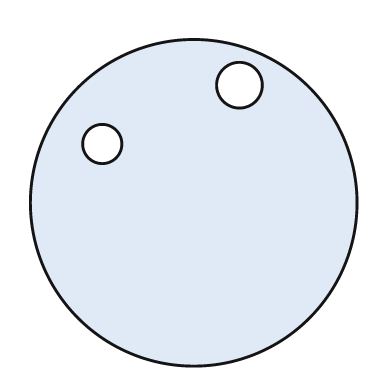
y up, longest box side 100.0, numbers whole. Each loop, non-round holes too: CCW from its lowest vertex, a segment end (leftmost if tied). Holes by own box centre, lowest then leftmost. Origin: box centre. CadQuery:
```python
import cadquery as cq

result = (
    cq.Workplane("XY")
    .moveTo(0.0, 0.0)
    .circle(50.0)
    .moveTo(-28.0, 18.0)
    .circle(6.0)
    .moveTo(14.0, 36.0)
    .circle(7.0)
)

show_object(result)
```